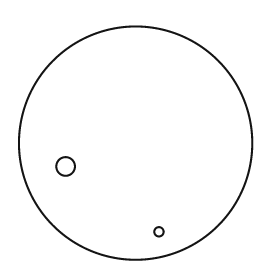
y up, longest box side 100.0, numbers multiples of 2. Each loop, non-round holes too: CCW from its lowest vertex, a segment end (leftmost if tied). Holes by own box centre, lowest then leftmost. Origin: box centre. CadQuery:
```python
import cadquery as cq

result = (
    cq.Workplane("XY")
    .moveTo(0.0, 0.0)
    .circle(50.0)
    .moveTo(10.0, -38.0)
    .circle(2.0)
    .moveTo(-30.0, -10.0)
    .circle(4.0)
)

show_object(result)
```